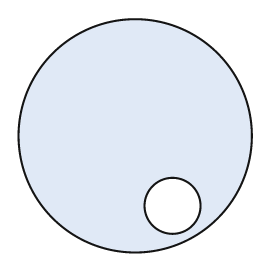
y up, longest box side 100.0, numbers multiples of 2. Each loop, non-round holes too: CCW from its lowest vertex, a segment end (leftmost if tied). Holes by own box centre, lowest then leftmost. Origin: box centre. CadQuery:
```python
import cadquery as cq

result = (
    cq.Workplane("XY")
    .moveTo(0.0, 0.0)
    .circle(50.0)
    .moveTo(16.0, -30.0)
    .circle(12.0)
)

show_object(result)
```